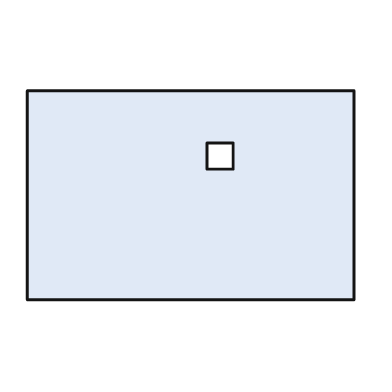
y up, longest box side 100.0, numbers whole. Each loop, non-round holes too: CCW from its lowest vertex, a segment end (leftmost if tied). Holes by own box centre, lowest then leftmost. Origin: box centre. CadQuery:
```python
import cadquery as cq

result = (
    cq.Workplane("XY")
    .moveTo(-50.0, -32.0)
    .lineTo(50.0, -32.0)
    .lineTo(50.0, 32.0)
    .lineTo(-50.0, 32.0)
    .close()
    .moveTo(5.0, 8.0)
    .lineTo(13.0, 8.0)
    .lineTo(13.0, 16.0)
    .lineTo(5.0, 16.0)
    .close()
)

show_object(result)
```